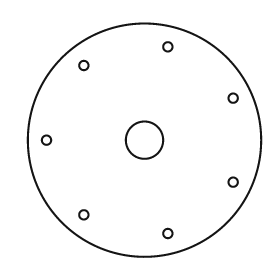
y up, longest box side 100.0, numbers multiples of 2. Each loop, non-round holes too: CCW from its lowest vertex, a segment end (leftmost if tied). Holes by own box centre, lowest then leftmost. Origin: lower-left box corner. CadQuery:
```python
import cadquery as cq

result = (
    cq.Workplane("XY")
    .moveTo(50.0, 50.0)
    .circle(50.0)
    .moveTo(60.0, 10.0)
    .circle(2.0)
    .moveTo(24.0, 18.0)
    .circle(2.0)
    .moveTo(88.0, 32.0)
    .circle(2.0)
    .moveTo(8.0, 50.0)
    .circle(2.0)
    .moveTo(50.0, 50.0)
    .circle(8.0)
    .moveTo(88.0, 68.0)
    .circle(2.0)
    .moveTo(24.0, 82.0)
    .circle(2.0)
    .moveTo(60.0, 90.0)
    .circle(2.0)
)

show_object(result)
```